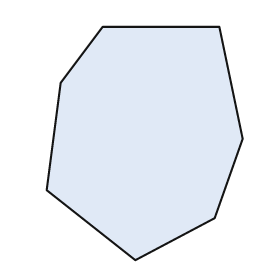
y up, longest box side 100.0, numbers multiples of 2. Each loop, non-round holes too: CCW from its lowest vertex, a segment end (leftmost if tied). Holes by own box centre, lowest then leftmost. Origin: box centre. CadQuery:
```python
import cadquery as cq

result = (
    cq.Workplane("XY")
    .moveTo(-4.0, -50.0)
    .lineTo(30.0, -32.0)
    .lineTo(42.0, 2.0)
    .lineTo(32.0, 50.0)
    .lineTo(-18.0, 50.0)
    .lineTo(-36.0, 26.0)
    .lineTo(-42.0, -20.0)
    .close()
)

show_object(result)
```